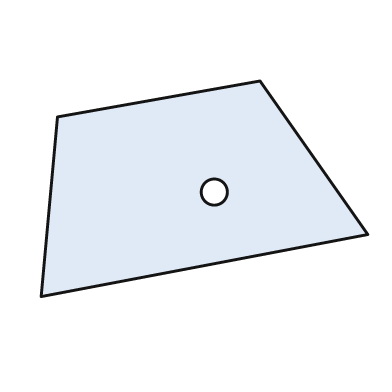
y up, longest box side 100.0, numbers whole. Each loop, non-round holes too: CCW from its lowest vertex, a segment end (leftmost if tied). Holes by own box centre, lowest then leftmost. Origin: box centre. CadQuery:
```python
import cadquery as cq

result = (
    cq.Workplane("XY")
    .moveTo(-50.0, -33.0)
    .lineTo(50.0, -14.0)
    .lineTo(17.0, 33.0)
    .lineTo(-45.0, 22.0)
    .close()
    .moveTo(3.0, -1.0)
    .circle(4.0)
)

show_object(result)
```